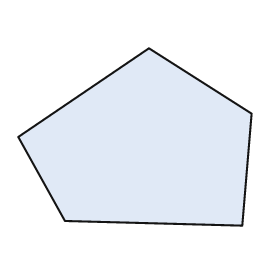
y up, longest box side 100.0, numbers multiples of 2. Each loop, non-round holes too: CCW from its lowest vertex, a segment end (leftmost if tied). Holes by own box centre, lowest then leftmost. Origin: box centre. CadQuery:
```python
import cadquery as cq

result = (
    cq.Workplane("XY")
    .moveTo(46.0, -38.0)
    .lineTo(50.0, 10.0)
    .lineTo(6.0, 38.0)
    .lineTo(-50.0, 0.0)
    .lineTo(-30.0, -36.0)
    .close()
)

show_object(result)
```